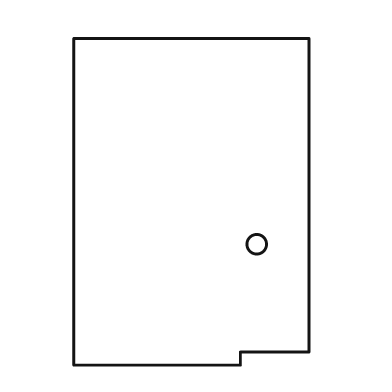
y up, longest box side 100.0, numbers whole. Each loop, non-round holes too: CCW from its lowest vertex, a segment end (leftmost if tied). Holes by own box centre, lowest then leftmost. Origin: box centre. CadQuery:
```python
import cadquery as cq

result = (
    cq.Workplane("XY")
    .moveTo(-36.0, -50.0)
    .lineTo(15.0, -50.0)
    .lineTo(15.0, -46.0)
    .lineTo(36.0, -46.0)
    .lineTo(36.0, 50.0)
    .lineTo(-36.0, 50.0)
    .close()
    .moveTo(20.0, -13.0)
    .circle(3.0)
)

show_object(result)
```